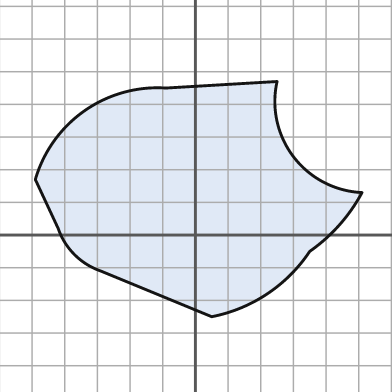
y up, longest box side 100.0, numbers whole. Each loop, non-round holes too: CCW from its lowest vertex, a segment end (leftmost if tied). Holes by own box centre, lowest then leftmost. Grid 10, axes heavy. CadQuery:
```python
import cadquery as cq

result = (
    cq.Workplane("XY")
    .moveTo(5.0, -25.0)
    .threePointArc((22.0, -18.0), (35.0, -5.0))
    .threePointArc((44.0, 3.0), (51.0, 13.0))
    .threePointArc((30.0, 24.0), (25.0, 47.0))
    .lineTo(-9.0, 45.0)
    .threePointArc((-34.0, 38.0), (-49.0, 17.0))
    .lineTo(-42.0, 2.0)
    .threePointArc((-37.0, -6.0), (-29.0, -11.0))
    .close()
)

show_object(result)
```